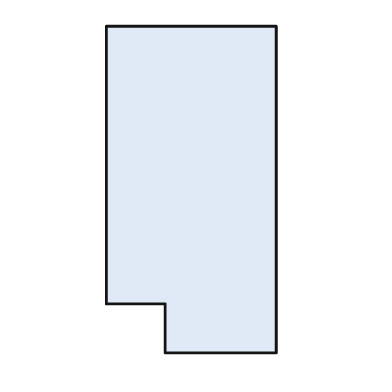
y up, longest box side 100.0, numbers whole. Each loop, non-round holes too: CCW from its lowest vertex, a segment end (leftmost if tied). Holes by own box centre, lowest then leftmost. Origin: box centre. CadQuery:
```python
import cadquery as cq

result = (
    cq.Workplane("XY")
    .moveTo(-8.0, -50.0)
    .lineTo(26.0, -50.0)
    .lineTo(26.0, 50.0)
    .lineTo(-26.0, 50.0)
    .lineTo(-26.0, -35.0)
    .lineTo(-8.0, -35.0)
    .close()
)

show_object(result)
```